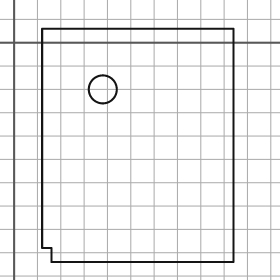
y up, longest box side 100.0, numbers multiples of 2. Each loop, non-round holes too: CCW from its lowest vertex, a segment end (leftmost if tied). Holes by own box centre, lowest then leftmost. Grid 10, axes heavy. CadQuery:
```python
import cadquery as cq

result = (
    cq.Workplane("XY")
    .moveTo(16.0, -94.0)
    .lineTo(94.0, -94.0)
    .lineTo(94.0, 6.0)
    .lineTo(12.0, 6.0)
    .lineTo(12.0, -88.0)
    .lineTo(16.0, -88.0)
    .close()
    .moveTo(38.0, -20.0)
    .circle(6.0)
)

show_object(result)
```